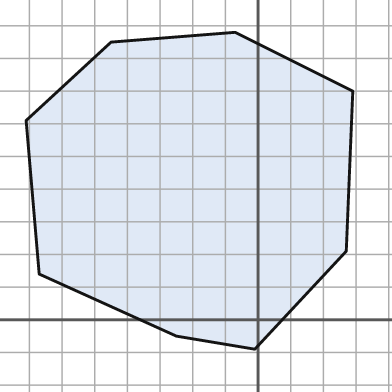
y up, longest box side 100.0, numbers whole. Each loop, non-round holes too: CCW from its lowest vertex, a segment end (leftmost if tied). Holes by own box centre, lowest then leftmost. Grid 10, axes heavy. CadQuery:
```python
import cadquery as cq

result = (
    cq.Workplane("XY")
    .moveTo(-1.0, -9.0)
    .lineTo(27.0, 21.0)
    .lineTo(29.0, 70.0)
    .lineTo(-7.0, 88.0)
    .lineTo(-45.0, 85.0)
    .lineTo(-71.0, 61.0)
    .lineTo(-67.0, 14.0)
    .lineTo(-25.0, -5.0)
    .close()
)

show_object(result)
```